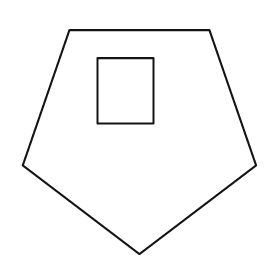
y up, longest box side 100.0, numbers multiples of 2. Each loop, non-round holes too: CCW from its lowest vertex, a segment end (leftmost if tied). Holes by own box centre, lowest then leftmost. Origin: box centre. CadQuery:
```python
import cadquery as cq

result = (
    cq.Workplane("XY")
    .moveTo(0.0, -48.0)
    .lineTo(50.0, -10.0)
    .lineTo(30.0, 48.0)
    .lineTo(-30.0, 48.0)
    .lineTo(-50.0, -10.0)
    .close()
    .moveTo(-18.0, 8.0)
    .lineTo(6.0, 8.0)
    .lineTo(6.0, 36.0)
    .lineTo(-18.0, 36.0)
    .close()
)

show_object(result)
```